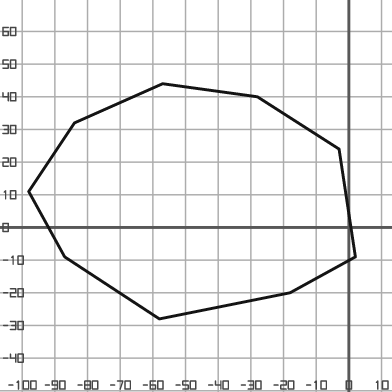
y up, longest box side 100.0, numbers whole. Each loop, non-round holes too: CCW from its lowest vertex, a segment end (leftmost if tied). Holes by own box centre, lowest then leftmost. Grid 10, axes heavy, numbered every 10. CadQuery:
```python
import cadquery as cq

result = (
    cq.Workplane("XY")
    .moveTo(-58.0, -28.0)
    .lineTo(-18.0, -20.0)
    .lineTo(2.0, -9.0)
    .lineTo(-3.0, 24.0)
    .lineTo(-28.0, 40.0)
    .lineTo(-57.0, 44.0)
    .lineTo(-84.0, 32.0)
    .lineTo(-98.0, 11.0)
    .lineTo(-87.0, -9.0)
    .close()
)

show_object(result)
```